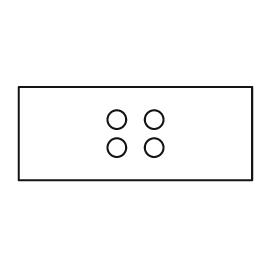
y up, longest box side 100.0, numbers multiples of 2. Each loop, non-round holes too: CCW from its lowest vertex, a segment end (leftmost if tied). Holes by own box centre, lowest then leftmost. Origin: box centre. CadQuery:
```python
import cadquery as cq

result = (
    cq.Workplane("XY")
    .moveTo(-50.0, -20.0)
    .lineTo(50.0, -20.0)
    .lineTo(50.0, 20.0)
    .lineTo(-50.0, 20.0)
    .close()
    .moveTo(-8.0, -6.0)
    .circle(4.0)
    .moveTo(8.0, -6.0)
    .circle(4.0)
    .moveTo(-8.0, 6.0)
    .circle(4.0)
    .moveTo(8.0, 6.0)
    .circle(4.0)
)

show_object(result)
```